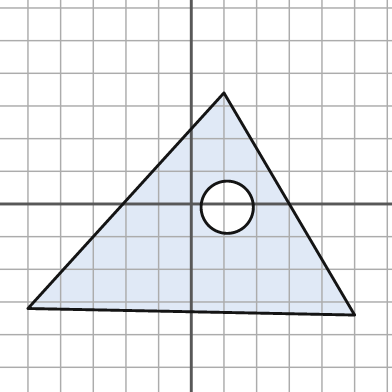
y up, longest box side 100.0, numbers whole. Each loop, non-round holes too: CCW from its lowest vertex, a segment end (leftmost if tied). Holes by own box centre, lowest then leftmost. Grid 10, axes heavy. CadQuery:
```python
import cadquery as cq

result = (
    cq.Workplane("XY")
    .moveTo(50.0, -34.0)
    .lineTo(10.0, 34.0)
    .lineTo(-50.0, -32.0)
    .close()
    .moveTo(11.0, -1.0)
    .circle(8.0)
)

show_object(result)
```